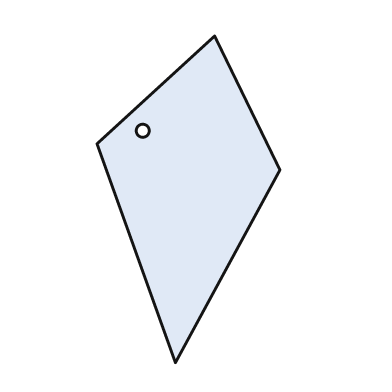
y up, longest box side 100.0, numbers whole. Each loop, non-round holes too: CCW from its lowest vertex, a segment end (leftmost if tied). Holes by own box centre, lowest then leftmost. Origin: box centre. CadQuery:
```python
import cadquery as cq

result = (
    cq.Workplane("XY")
    .moveTo(-4.0, -50.0)
    .lineTo(28.0, 9.0)
    .lineTo(8.0, 50.0)
    .lineTo(-28.0, 17.0)
    .close()
    .moveTo(-14.0, 21.0)
    .circle(2.0)
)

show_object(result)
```